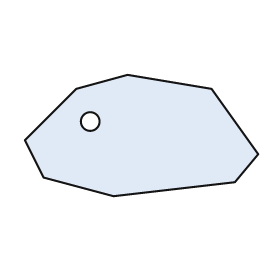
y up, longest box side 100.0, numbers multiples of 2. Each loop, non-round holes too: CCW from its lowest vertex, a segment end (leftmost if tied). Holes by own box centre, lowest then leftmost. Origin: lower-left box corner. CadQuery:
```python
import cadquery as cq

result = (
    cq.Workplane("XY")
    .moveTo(38.0, 0.0)
    .lineTo(90.0, 6.0)
    .lineTo(100.0, 18.0)
    .lineTo(80.0, 46.0)
    .lineTo(44.0, 52.0)
    .lineTo(22.0, 46.0)
    .lineTo(0.0, 24.0)
    .lineTo(8.0, 8.0)
    .close()
    .moveTo(28.0, 32.0)
    .circle(4.0)
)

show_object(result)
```